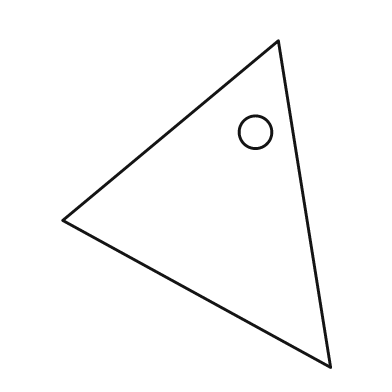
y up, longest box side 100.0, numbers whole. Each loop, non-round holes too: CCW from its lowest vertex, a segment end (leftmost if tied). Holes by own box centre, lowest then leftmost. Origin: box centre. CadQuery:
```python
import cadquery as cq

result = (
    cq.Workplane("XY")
    .moveTo(41.0, -50.0)
    .lineTo(25.0, 50.0)
    .lineTo(-41.0, -5.0)
    .close()
    .moveTo(18.0, 22.0)
    .circle(5.0)
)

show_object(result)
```